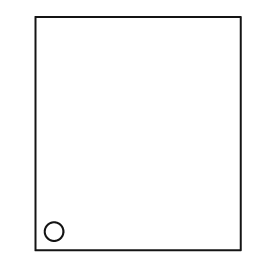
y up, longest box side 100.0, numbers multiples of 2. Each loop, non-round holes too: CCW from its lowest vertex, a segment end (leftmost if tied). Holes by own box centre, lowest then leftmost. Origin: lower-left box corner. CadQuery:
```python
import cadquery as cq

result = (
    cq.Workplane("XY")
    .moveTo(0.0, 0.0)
    .lineTo(88.0, 0.0)
    .lineTo(88.0, 100.0)
    .lineTo(0.0, 100.0)
    .close()
    .moveTo(8.0, 8.0)
    .circle(4.0)
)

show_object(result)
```